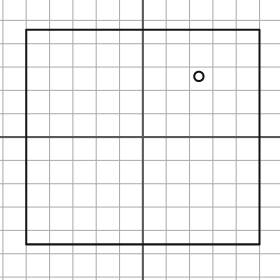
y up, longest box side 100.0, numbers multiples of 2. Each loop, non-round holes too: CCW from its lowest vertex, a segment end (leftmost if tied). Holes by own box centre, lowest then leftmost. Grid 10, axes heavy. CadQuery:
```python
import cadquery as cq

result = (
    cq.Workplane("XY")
    .moveTo(-50.0, -46.0)
    .lineTo(50.0, -46.0)
    .lineTo(50.0, 46.0)
    .lineTo(-50.0, 46.0)
    .close()
    .moveTo(24.0, 26.0)
    .circle(2.0)
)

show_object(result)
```